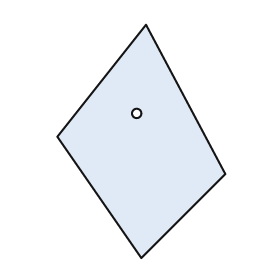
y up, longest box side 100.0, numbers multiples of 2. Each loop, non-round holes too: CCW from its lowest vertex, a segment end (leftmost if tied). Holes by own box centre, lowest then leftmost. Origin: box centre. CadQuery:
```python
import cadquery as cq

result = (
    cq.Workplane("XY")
    .moveTo(0.0, -50.0)
    .lineTo(36.0, -14.0)
    .lineTo(2.0, 50.0)
    .lineTo(-36.0, 2.0)
    .close()
    .moveTo(-2.0, 12.0)
    .circle(2.0)
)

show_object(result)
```